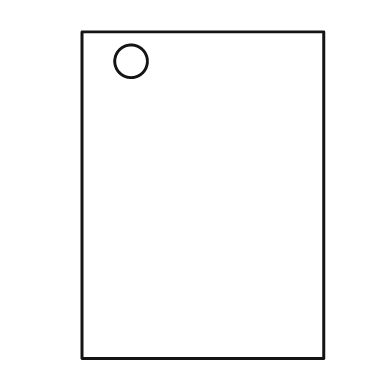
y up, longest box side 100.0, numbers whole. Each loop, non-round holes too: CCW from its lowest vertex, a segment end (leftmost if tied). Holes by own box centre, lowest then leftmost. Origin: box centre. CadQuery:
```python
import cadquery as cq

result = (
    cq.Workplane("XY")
    .moveTo(-37.0, -50.0)
    .lineTo(37.0, -50.0)
    .lineTo(37.0, 50.0)
    .lineTo(-37.0, 50.0)
    .close()
    .moveTo(-22.0, 41.0)
    .circle(5.0)
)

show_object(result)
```